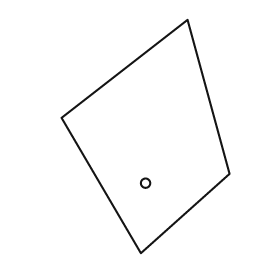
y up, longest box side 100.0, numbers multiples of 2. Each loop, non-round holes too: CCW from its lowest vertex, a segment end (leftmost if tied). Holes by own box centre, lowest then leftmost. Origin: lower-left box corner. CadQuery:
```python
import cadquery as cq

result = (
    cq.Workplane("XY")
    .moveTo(34.0, 0.0)
    .lineTo(72.0, 34.0)
    .lineTo(54.0, 100.0)
    .lineTo(0.0, 58.0)
    .close()
    .moveTo(36.0, 30.0)
    .circle(2.0)
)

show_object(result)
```